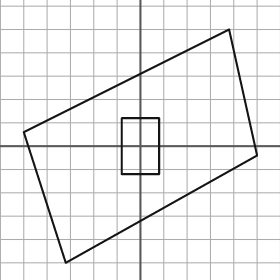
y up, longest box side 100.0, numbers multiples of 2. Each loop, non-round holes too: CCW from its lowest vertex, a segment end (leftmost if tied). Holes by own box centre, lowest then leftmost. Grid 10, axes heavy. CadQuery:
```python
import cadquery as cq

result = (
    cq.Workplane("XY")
    .moveTo(-32.0, -50.0)
    .lineTo(50.0, -4.0)
    .lineTo(38.0, 50.0)
    .lineTo(-50.0, 6.0)
    .close()
    .moveTo(-8.0, -12.0)
    .lineTo(8.0, -12.0)
    .lineTo(8.0, 12.0)
    .lineTo(-8.0, 12.0)
    .close()
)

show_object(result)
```